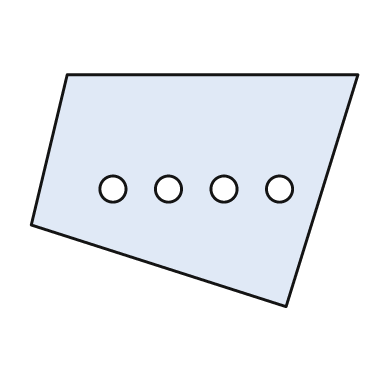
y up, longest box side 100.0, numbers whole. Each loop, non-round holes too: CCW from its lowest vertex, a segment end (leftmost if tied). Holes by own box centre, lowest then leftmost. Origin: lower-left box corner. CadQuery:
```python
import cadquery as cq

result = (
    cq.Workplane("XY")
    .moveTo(78.0, 0.0)
    .lineTo(100.0, 71.0)
    .lineTo(11.0, 71.0)
    .lineTo(0.0, 25.0)
    .close()
    .moveTo(25.0, 36.0)
    .circle(4.0)
    .moveTo(42.0, 36.0)
    .circle(4.0)
    .moveTo(59.0, 36.0)
    .circle(4.0)
    .moveTo(76.0, 36.0)
    .circle(4.0)
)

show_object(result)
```